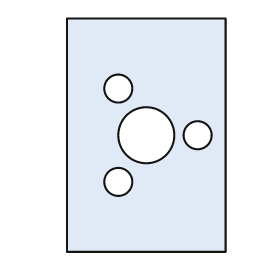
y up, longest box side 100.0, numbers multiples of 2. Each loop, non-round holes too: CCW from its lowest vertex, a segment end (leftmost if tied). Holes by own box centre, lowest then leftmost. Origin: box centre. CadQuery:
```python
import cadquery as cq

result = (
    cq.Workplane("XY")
    .moveTo(-34.0, -50.0)
    .lineTo(34.0, -50.0)
    .lineTo(34.0, 50.0)
    .lineTo(-34.0, 50.0)
    .close()
    .moveTo(-12.0, -20.0)
    .circle(6.0)
    .moveTo(0.0, 0.0)
    .circle(12.0)
    .moveTo(22.0, 0.0)
    .circle(6.0)
    .moveTo(-12.0, 20.0)
    .circle(6.0)
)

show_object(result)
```